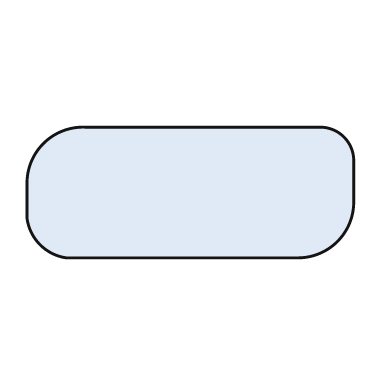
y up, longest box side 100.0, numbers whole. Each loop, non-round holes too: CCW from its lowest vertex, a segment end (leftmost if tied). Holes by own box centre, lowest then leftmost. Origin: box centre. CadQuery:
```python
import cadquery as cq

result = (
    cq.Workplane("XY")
    .moveTo(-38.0, -20.0)
    .lineTo(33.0, -20.0)
    .threePointArc((45.0, -15.0), (50.0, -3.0))
    .lineTo(50.0, 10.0)
    .threePointArc((47.0, 17.0), (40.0, 20.0))
    .lineTo(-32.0, 20.0)
    .threePointArc((-45.0, 15.0), (-50.0, 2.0))
    .lineTo(-50.0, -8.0)
    .threePointArc((-46.0, -16.0), (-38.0, -20.0))
    .close()
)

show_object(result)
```